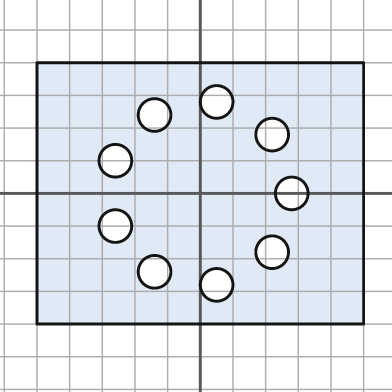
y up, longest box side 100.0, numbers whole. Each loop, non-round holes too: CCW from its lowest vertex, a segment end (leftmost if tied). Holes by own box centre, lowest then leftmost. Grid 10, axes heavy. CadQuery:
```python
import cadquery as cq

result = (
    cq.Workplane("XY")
    .moveTo(-50.0, -40.0)
    .lineTo(50.0, -40.0)
    .lineTo(50.0, 40.0)
    .lineTo(-50.0, 40.0)
    .close()
    .moveTo(5.0, -28.0)
    .circle(5.0)
    .moveTo(-14.0, -24.0)
    .circle(5.0)
    .moveTo(22.0, -18.0)
    .circle(5.0)
    .moveTo(-26.0, -10.0)
    .circle(5.0)
    .moveTo(28.0, 0.0)
    .circle(5.0)
    .moveTo(-26.0, 10.0)
    .circle(5.0)
    .moveTo(22.0, 18.0)
    .circle(5.0)
    .moveTo(-14.0, 24.0)
    .circle(5.0)
    .moveTo(5.0, 28.0)
    .circle(5.0)
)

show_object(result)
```